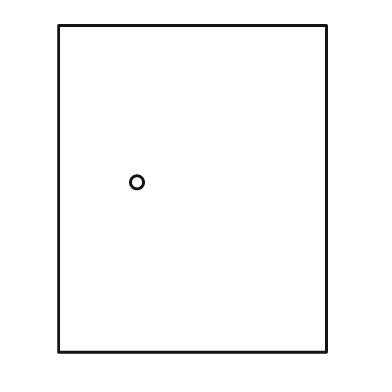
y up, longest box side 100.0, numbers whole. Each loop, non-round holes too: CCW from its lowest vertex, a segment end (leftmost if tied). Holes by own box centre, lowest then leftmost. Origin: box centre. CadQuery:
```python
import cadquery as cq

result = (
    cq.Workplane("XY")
    .moveTo(-41.0, -50.0)
    .lineTo(41.0, -50.0)
    .lineTo(41.0, 50.0)
    .lineTo(-41.0, 50.0)
    .close()
    .moveTo(-17.0, 2.0)
    .circle(2.0)
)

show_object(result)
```